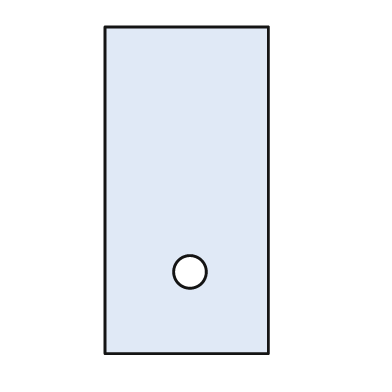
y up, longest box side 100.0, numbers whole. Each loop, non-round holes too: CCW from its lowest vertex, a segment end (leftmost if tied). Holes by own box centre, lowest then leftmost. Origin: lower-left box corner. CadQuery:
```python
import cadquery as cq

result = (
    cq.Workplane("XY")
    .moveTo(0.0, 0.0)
    .lineTo(50.0, 0.0)
    .lineTo(50.0, 100.0)
    .lineTo(0.0, 100.0)
    .close()
    .moveTo(26.0, 25.0)
    .circle(5.0)
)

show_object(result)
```